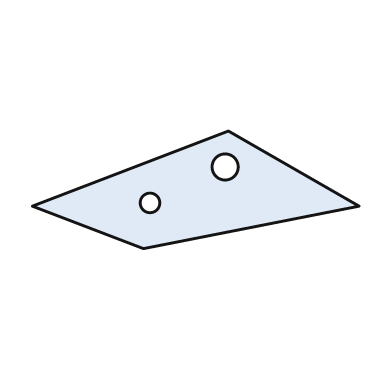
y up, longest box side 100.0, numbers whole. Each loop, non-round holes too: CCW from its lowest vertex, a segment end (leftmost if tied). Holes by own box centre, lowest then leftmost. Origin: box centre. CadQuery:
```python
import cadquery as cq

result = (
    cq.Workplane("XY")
    .moveTo(-16.0, -18.0)
    .lineTo(50.0, -5.0)
    .lineTo(10.0, 18.0)
    .lineTo(-50.0, -5.0)
    .close()
    .moveTo(-14.0, -4.0)
    .circle(3.0)
    .moveTo(9.0, 7.0)
    .circle(4.0)
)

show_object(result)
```